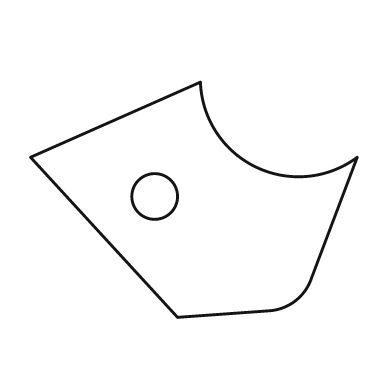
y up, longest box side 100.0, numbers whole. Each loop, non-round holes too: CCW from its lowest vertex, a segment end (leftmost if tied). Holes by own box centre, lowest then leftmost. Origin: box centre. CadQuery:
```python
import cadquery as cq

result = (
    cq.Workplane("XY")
    .moveTo(-5.0, -36.0)
    .lineTo(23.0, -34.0)
    .threePointArc((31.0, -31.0), (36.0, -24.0))
    .lineTo(50.0, 13.0)
    .threePointArc((19.0, 10.0), (2.0, 36.0))
    .lineTo(-50.0, 13.0)
    .close()
    .moveTo(-12.0, 1.0)
    .circle(7.0)
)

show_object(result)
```